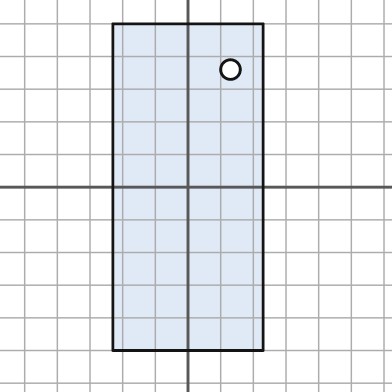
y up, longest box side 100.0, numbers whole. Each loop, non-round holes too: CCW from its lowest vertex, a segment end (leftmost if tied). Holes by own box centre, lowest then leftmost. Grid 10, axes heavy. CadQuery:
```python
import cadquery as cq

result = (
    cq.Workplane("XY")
    .moveTo(-23.0, -50.0)
    .lineTo(23.0, -50.0)
    .lineTo(23.0, 50.0)
    .lineTo(-23.0, 50.0)
    .close()
    .moveTo(13.0, 36.0)
    .circle(3.0)
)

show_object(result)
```